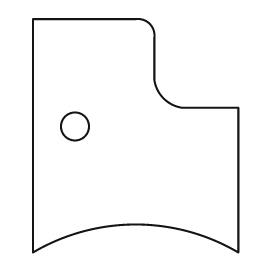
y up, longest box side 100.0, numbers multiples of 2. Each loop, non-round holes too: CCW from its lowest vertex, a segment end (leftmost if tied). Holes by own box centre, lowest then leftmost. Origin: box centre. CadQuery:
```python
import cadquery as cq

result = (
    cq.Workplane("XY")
    .moveTo(-44.0, -50.0)
    .threePointArc((0.0, -38.0), (44.0, -50.0))
    .lineTo(44.0, 12.0)
    .lineTo(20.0, 12.0)
    .threePointArc((12.0, 16.0), (8.0, 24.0))
    .lineTo(8.0, 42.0)
    .threePointArc((6.0, 48.0), (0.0, 50.0))
    .lineTo(-44.0, 50.0)
    .close()
    .moveTo(-26.0, 4.0)
    .circle(6.0)
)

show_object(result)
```